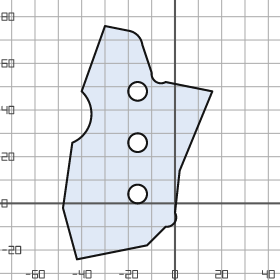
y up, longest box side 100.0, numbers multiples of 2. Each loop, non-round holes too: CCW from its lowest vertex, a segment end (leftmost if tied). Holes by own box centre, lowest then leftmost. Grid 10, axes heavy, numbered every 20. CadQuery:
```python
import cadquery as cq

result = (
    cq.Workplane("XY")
    .moveTo(-42.0, -24.0)
    .lineTo(-12.0, -18.0)
    .lineTo(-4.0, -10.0)
    .threePointArc((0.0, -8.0), (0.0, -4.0))
    .lineTo(2.0, 14.0)
    .lineTo(16.0, 48.0)
    .lineTo(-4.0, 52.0)
    .threePointArc((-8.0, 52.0), (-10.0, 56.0))
    .lineTo(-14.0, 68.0)
    .threePointArc((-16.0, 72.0), (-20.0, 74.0))
    .lineTo(-30.0, 76.0)
    .lineTo(-40.0, 48.0)
    .threePointArc((-36.0, 36.0), (-44.0, 26.0))
    .lineTo(-48.0, -2.0)
    .close()
    .moveTo(-16.0, 4.0)
    .circle(4.0)
    .moveTo(-16.0, 26.0)
    .circle(4.0)
    .moveTo(-16.0, 48.0)
    .circle(4.0)
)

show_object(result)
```